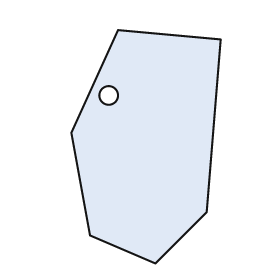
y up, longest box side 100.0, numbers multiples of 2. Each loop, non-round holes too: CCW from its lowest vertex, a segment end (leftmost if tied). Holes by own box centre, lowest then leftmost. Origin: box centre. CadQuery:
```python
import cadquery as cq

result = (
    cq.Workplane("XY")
    .moveTo(4.0, -50.0)
    .lineTo(26.0, -28.0)
    .lineTo(32.0, 46.0)
    .lineTo(-12.0, 50.0)
    .lineTo(-32.0, 6.0)
    .lineTo(-24.0, -38.0)
    .close()
    .moveTo(-16.0, 22.0)
    .circle(4.0)
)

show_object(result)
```